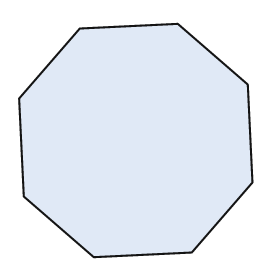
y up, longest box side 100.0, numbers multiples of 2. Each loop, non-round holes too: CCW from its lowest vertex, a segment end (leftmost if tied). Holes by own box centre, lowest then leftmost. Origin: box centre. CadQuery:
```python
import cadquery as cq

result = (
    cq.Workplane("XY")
    .moveTo(-18.0, -50.0)
    .lineTo(24.0, -48.0)
    .lineTo(50.0, -18.0)
    .lineTo(48.0, 24.0)
    .lineTo(18.0, 50.0)
    .lineTo(-24.0, 48.0)
    .lineTo(-50.0, 18.0)
    .lineTo(-48.0, -24.0)
    .close()
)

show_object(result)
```